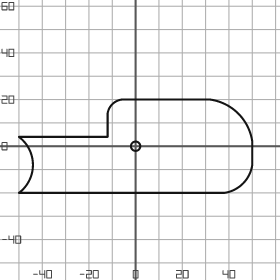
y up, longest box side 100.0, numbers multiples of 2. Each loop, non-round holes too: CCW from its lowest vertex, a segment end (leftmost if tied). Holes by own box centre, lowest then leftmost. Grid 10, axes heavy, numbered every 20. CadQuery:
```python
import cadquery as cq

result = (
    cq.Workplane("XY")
    .moveTo(-50.0, -20.0)
    .lineTo(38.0, -20.0)
    .threePointArc((46.0, -16.0), (50.0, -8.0))
    .lineTo(50.0, 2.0)
    .threePointArc((44.0, 14.0), (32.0, 20.0))
    .lineTo(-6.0, 20.0)
    .threePointArc((-10.0, 18.0), (-12.0, 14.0))
    .lineTo(-12.0, 4.0)
    .lineTo(-50.0, 4.0)
    .threePointArc((-44.0, -8.0), (-50.0, -20.0))
    .close()
    .moveTo(0.0, 0.0)
    .circle(2.0)
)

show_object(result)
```